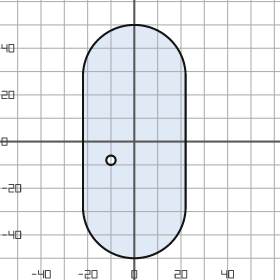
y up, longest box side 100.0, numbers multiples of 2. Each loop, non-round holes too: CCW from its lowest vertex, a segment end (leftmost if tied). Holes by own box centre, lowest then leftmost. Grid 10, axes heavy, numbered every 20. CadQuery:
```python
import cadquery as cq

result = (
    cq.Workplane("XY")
    .moveTo(-22.0, -28.0)
    .threePointArc((0.0, -50.0), (22.0, -28.0))
    .lineTo(22.0, 28.0)
    .threePointArc((0.0, 50.0), (-22.0, 28.0))
    .close()
    .moveTo(-10.0, -8.0)
    .circle(2.0)
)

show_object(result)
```